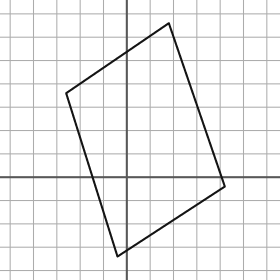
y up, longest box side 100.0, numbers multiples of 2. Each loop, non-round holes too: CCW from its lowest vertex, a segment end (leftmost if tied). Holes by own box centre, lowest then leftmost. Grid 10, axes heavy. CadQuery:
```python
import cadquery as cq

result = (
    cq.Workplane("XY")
    .moveTo(-4.0, -34.0)
    .lineTo(42.0, -4.0)
    .lineTo(18.0, 66.0)
    .lineTo(-26.0, 36.0)
    .close()
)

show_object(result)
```